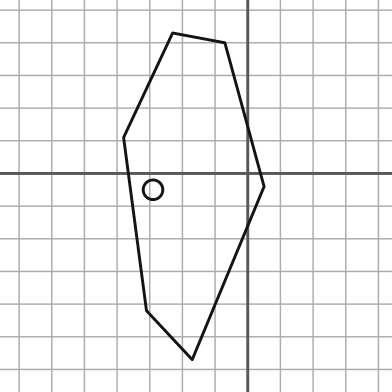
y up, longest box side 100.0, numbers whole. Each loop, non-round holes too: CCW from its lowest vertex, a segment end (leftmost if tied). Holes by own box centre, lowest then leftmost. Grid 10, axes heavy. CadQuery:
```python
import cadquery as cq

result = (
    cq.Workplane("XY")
    .moveTo(-17.0, -57.0)
    .lineTo(5.0, -4.0)
    .lineTo(-7.0, 40.0)
    .lineTo(-23.0, 43.0)
    .lineTo(-38.0, 11.0)
    .lineTo(-31.0, -42.0)
    .close()
    .moveTo(-29.0, -5.0)
    .circle(3.0)
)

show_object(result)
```